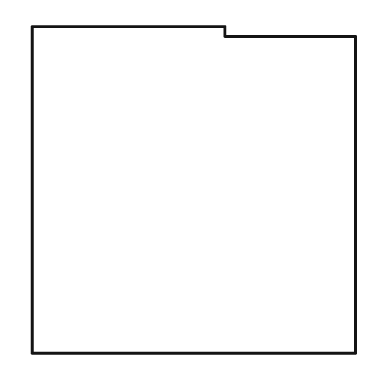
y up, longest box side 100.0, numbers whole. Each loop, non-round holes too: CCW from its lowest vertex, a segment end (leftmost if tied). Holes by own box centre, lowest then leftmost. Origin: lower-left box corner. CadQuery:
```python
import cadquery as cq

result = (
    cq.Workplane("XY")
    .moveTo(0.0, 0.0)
    .lineTo(99.0, 0.0)
    .lineTo(99.0, 97.0)
    .lineTo(59.0, 97.0)
    .lineTo(59.0, 100.0)
    .lineTo(0.0, 100.0)
    .close()
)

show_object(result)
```